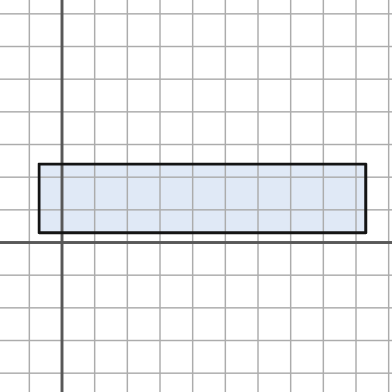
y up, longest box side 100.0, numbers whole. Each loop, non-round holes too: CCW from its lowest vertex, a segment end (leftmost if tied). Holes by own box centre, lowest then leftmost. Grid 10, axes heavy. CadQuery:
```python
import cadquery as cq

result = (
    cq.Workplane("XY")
    .moveTo(-7.0, 3.0)
    .lineTo(93.0, 3.0)
    .lineTo(93.0, 24.0)
    .lineTo(-7.0, 24.0)
    .close()
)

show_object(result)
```